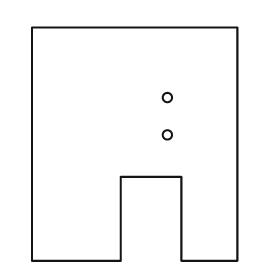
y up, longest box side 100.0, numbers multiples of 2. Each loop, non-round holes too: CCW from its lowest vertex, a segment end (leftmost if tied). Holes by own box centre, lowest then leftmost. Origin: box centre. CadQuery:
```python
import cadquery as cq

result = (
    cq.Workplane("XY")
    .moveTo(-44.0, -50.0)
    .lineTo(-6.0, -50.0)
    .lineTo(-6.0, -14.0)
    .lineTo(20.0, -14.0)
    .lineTo(20.0, -50.0)
    .lineTo(44.0, -50.0)
    .lineTo(44.0, 50.0)
    .lineTo(-44.0, 50.0)
    .close()
    .moveTo(14.0, 4.0)
    .circle(2.0)
    .moveTo(14.0, 20.0)
    .circle(2.0)
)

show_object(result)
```